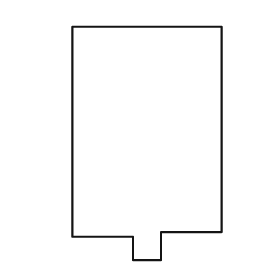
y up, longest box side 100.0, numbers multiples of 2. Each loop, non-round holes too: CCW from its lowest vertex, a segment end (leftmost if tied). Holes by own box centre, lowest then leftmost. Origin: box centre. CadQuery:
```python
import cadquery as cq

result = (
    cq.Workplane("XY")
    .moveTo(-6.0, -50.0)
    .lineTo(6.0, -50.0)
    .lineTo(6.0, -38.0)
    .lineTo(32.0, -38.0)
    .lineTo(32.0, 50.0)
    .lineTo(-32.0, 50.0)
    .lineTo(-32.0, -40.0)
    .lineTo(-6.0, -40.0)
    .close()
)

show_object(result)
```